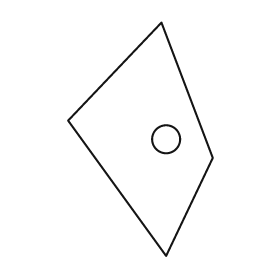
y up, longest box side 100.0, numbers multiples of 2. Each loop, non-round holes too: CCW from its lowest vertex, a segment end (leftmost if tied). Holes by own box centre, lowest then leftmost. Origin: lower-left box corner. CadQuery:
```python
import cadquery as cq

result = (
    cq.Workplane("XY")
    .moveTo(42.0, 0.0)
    .lineTo(62.0, 42.0)
    .lineTo(40.0, 100.0)
    .lineTo(0.0, 58.0)
    .close()
    .moveTo(42.0, 50.0)
    .circle(6.0)
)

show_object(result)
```